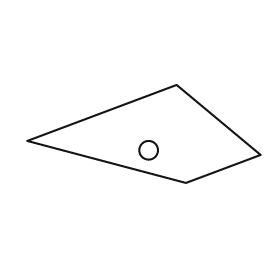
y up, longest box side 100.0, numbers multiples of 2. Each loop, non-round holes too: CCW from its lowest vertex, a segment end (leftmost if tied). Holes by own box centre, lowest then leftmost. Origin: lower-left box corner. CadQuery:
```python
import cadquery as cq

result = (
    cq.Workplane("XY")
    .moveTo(68.0, 0.0)
    .lineTo(100.0, 12.0)
    .lineTo(64.0, 42.0)
    .lineTo(0.0, 18.0)
    .close()
    .moveTo(52.0, 14.0)
    .circle(4.0)
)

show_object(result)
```